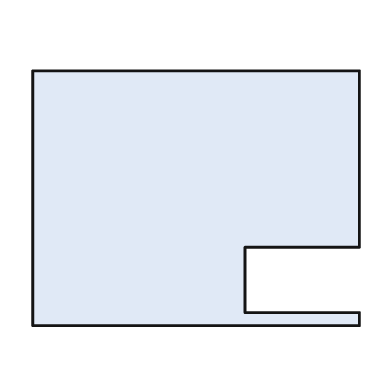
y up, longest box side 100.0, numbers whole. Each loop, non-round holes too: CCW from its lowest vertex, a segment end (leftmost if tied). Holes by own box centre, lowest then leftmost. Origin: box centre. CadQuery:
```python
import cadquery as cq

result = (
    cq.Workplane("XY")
    .moveTo(-50.0, -39.0)
    .lineTo(50.0, -39.0)
    .lineTo(50.0, -35.0)
    .lineTo(15.0, -35.0)
    .lineTo(15.0, -15.0)
    .lineTo(50.0, -15.0)
    .lineTo(50.0, 39.0)
    .lineTo(-50.0, 39.0)
    .close()
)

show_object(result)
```